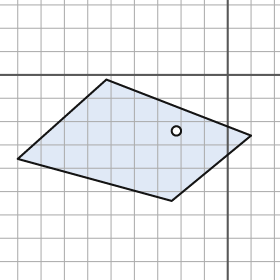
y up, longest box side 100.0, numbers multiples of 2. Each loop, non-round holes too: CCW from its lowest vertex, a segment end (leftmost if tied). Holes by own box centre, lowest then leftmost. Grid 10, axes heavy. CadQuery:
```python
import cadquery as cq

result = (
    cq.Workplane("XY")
    .moveTo(-24.0, -54.0)
    .lineTo(10.0, -26.0)
    .lineTo(-52.0, -2.0)
    .lineTo(-90.0, -36.0)
    .close()
    .moveTo(-22.0, -24.0)
    .circle(2.0)
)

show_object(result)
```